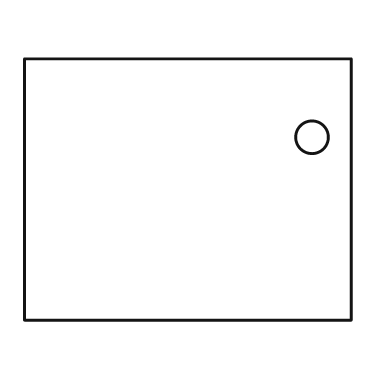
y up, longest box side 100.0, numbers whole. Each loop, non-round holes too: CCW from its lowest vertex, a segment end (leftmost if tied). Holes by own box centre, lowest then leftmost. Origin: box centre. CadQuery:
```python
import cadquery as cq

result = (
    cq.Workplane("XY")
    .moveTo(-50.0, -40.0)
    .lineTo(50.0, -40.0)
    .lineTo(50.0, 40.0)
    .lineTo(-50.0, 40.0)
    .close()
    .moveTo(38.0, 16.0)
    .circle(5.0)
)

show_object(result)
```